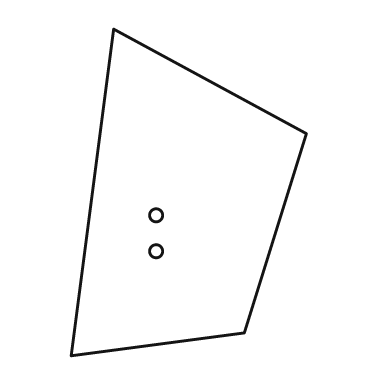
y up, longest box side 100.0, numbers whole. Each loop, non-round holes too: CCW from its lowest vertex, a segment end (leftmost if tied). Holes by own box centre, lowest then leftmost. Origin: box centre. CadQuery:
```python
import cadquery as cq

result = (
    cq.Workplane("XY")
    .moveTo(-36.0, -50.0)
    .lineTo(17.0, -43.0)
    .lineTo(36.0, 18.0)
    .lineTo(-23.0, 50.0)
    .close()
    .moveTo(-10.0, -18.0)
    .circle(2.0)
    .moveTo(-10.0, -7.0)
    .circle(2.0)
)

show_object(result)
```